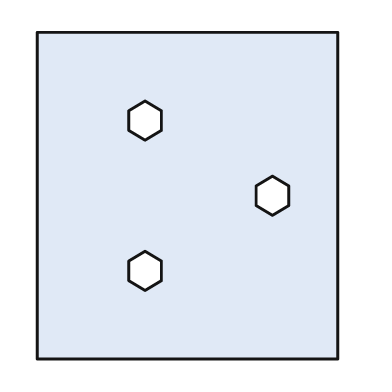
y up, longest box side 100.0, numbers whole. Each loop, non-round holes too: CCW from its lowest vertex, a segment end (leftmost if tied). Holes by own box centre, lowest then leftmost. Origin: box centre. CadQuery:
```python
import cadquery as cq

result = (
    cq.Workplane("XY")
    .moveTo(-46.0, -50.0)
    .lineTo(46.0, -50.0)
    .lineTo(46.0, 50.0)
    .lineTo(-46.0, 50.0)
    .close()
    .moveTo(-13.0, -29.0)
    .lineTo(-8.0, -26.0)
    .lineTo(-8.0, -20.0)
    .lineTo(-13.0, -17.0)
    .lineTo(-18.0, -20.0)
    .lineTo(-18.0, -26.0)
    .close()
    .moveTo(26.0, -6.0)
    .lineTo(31.0, -3.0)
    .lineTo(31.0, 3.0)
    .lineTo(26.0, 6.0)
    .lineTo(21.0, 3.0)
    .lineTo(21.0, -3.0)
    .close()
    .moveTo(-13.0, 17.0)
    .lineTo(-8.0, 20.0)
    .lineTo(-8.0, 26.0)
    .lineTo(-13.0, 29.0)
    .lineTo(-18.0, 26.0)
    .lineTo(-18.0, 20.0)
    .close()
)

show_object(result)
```